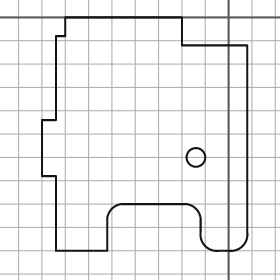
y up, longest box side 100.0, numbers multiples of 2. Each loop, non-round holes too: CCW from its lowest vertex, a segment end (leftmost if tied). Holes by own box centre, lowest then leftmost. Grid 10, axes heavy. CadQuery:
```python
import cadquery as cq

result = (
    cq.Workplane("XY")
    .moveTo(-74.0, -100.0)
    .lineTo(-52.0, -100.0)
    .lineTo(-52.0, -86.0)
    .threePointArc((-50.0, -82.0), (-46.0, -80.0))
    .lineTo(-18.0, -80.0)
    .threePointArc((-14.0, -82.0), (-12.0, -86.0))
    .lineTo(-12.0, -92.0)
    .threePointArc((-10.0, -98.0), (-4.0, -100.0))
    .lineTo(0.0, -100.0)
    .threePointArc((6.0, -98.0), (8.0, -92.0))
    .lineTo(8.0, -12.0)
    .lineTo(-20.0, -12.0)
    .lineTo(-20.0, 0.0)
    .lineTo(-70.0, 0.0)
    .lineTo(-70.0, -8.0)
    .lineTo(-74.0, -8.0)
    .lineTo(-74.0, -44.0)
    .lineTo(-80.0, -44.0)
    .lineTo(-80.0, -68.0)
    .lineTo(-74.0, -68.0)
    .close()
    .moveTo(-14.0, -60.0)
    .circle(4.0)
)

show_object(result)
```